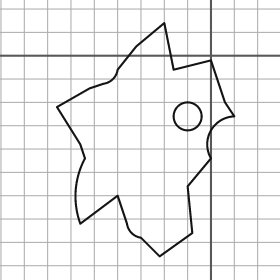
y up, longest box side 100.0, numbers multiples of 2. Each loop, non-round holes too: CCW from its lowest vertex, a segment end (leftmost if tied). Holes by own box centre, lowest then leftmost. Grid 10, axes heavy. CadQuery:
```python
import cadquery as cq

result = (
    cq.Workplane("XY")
    .moveTo(-22.0, -86.0)
    .lineTo(-8.0, -76.0)
    .lineTo(-10.0, -56.0)
    .lineTo(0.0, -44.0)
    .threePointArc((0.0, -32.0), (10.0, -26.0))
    .lineTo(6.0, -20.0)
    .lineTo(0.0, -2.0)
    .lineTo(-16.0, -6.0)
    .lineTo(-20.0, 14.0)
    .lineTo(-32.0, 4.0)
    .lineTo(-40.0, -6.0)
    .threePointArc((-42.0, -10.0), (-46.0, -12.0))
    .lineTo(-52.0, -14.0)
    .lineTo(-66.0, -22.0)
    .lineTo(-56.0, -38.0)
    .lineTo(-54.0, -44.0)
    .threePointArc((-58.0, -58.0), (-56.0, -72.0))
    .lineTo(-40.0, -60.0)
    .lineTo(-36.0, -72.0)
    .threePointArc((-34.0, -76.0), (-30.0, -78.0))
    .close()
    .moveTo(-10.0, -26.0)
    .circle(6.0)
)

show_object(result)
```